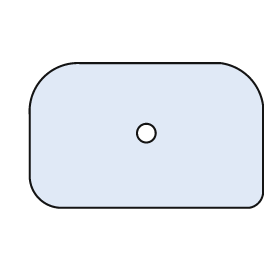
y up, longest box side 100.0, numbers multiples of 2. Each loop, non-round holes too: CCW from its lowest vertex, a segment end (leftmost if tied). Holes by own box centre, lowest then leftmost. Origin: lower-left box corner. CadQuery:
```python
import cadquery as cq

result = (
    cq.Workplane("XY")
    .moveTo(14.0, 0.0)
    .lineTo(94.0, 0.0)
    .threePointArc((98.0, 2.0), (100.0, 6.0))
    .lineTo(100.0, 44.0)
    .threePointArc((94.0, 56.0), (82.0, 62.0))
    .lineTo(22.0, 62.0)
    .threePointArc((6.0, 56.0), (0.0, 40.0))
    .lineTo(0.0, 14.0)
    .threePointArc((4.0, 4.0), (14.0, 0.0))
    .close()
    .moveTo(50.0, 32.0)
    .circle(4.0)
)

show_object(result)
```